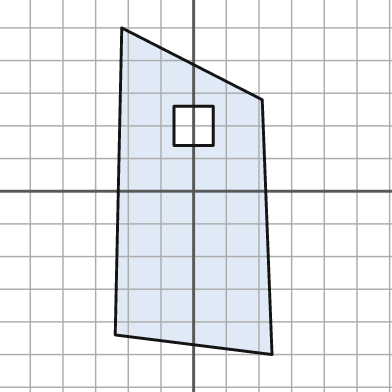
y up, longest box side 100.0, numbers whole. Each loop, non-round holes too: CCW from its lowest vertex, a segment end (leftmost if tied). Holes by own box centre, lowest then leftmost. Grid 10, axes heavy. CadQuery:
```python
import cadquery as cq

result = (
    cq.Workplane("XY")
    .moveTo(24.0, -50.0)
    .lineTo(21.0, 28.0)
    .lineTo(-22.0, 50.0)
    .lineTo(-24.0, -44.0)
    .close()
    .moveTo(-6.0, 14.0)
    .lineTo(6.0, 14.0)
    .lineTo(6.0, 26.0)
    .lineTo(-6.0, 26.0)
    .close()
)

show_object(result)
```